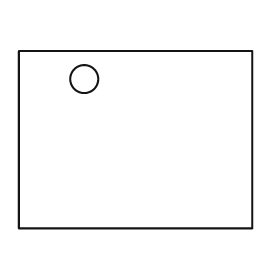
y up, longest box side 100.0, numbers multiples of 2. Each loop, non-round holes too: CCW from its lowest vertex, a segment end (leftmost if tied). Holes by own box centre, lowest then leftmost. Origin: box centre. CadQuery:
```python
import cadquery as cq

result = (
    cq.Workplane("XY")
    .moveTo(-50.0, -38.0)
    .lineTo(50.0, -38.0)
    .lineTo(50.0, 38.0)
    .lineTo(-50.0, 38.0)
    .close()
    .moveTo(-22.0, 26.0)
    .circle(6.0)
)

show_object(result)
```